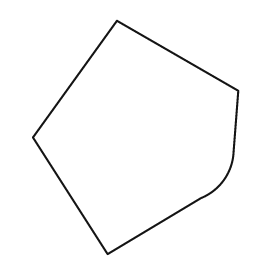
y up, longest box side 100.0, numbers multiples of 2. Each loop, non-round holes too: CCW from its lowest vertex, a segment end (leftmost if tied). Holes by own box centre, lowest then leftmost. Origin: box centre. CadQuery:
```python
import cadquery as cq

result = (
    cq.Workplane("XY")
    .moveTo(-12.0, -50.0)
    .lineTo(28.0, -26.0)
    .threePointArc((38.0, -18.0), (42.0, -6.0))
    .lineTo(44.0, 20.0)
    .lineTo(-8.0, 50.0)
    .lineTo(-44.0, 0.0)
    .close()
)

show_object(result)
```